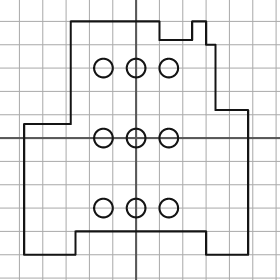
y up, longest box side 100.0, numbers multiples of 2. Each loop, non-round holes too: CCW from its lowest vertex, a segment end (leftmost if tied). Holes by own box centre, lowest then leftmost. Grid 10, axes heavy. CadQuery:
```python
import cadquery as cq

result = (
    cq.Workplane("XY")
    .moveTo(-48.0, -50.0)
    .lineTo(-26.0, -50.0)
    .lineTo(-26.0, -40.0)
    .lineTo(30.0, -40.0)
    .lineTo(30.0, -50.0)
    .lineTo(48.0, -50.0)
    .lineTo(48.0, 12.0)
    .lineTo(34.0, 12.0)
    .lineTo(34.0, 40.0)
    .lineTo(30.0, 40.0)
    .lineTo(30.0, 50.0)
    .lineTo(24.0, 50.0)
    .lineTo(24.0, 42.0)
    .lineTo(10.0, 42.0)
    .lineTo(10.0, 50.0)
    .lineTo(-28.0, 50.0)
    .lineTo(-28.0, 6.0)
    .lineTo(-48.0, 6.0)
    .close()
    .moveTo(-14.0, -30.0)
    .circle(4.0)
    .moveTo(0.0, -30.0)
    .circle(4.0)
    .moveTo(14.0, -30.0)
    .circle(4.0)
    .moveTo(-14.0, 0.0)
    .circle(4.0)
    .moveTo(0.0, 0.0)
    .circle(4.0)
    .moveTo(14.0, 0.0)
    .circle(4.0)
    .moveTo(-14.0, 30.0)
    .circle(4.0)
    .moveTo(0.0, 30.0)
    .circle(4.0)
    .moveTo(14.0, 30.0)
    .circle(4.0)
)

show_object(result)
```